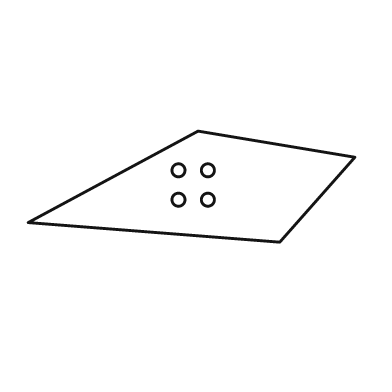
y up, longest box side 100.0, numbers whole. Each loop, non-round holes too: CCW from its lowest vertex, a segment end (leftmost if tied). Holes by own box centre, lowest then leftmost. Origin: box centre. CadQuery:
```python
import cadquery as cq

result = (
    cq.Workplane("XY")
    .moveTo(27.0, -17.0)
    .lineTo(50.0, 9.0)
    .lineTo(2.0, 17.0)
    .lineTo(-50.0, -11.0)
    .close()
    .moveTo(-4.0, -4.0)
    .circle(2.0)
    .moveTo(5.0, -4.0)
    .circle(2.0)
    .moveTo(-4.0, 5.0)
    .circle(2.0)
    .moveTo(5.0, 5.0)
    .circle(2.0)
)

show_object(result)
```